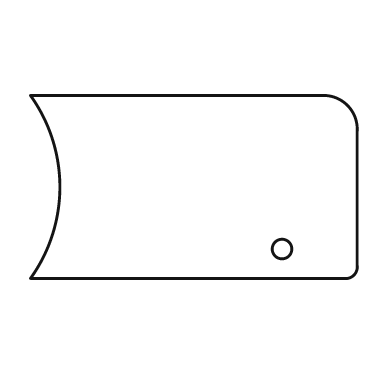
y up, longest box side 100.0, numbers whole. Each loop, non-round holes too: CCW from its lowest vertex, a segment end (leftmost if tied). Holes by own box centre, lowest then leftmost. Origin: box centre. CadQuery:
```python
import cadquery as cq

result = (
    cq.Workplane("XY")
    .moveTo(-50.0, -28.0)
    .lineTo(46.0, -28.0)
    .threePointArc((49.0, -27.0), (50.0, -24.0))
    .lineTo(50.0, 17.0)
    .threePointArc((47.0, 25.0), (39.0, 28.0))
    .lineTo(-50.0, 28.0)
    .threePointArc((-41.0, 0.0), (-50.0, -28.0))
    .close()
    .moveTo(27.0, -19.0)
    .circle(3.0)
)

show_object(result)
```